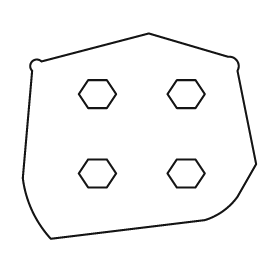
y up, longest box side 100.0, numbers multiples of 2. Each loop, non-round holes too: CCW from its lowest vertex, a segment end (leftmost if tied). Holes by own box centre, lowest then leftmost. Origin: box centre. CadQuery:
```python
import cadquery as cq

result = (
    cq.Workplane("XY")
    .moveTo(-38.0, -44.0)
    .lineTo(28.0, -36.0)
    .threePointArc((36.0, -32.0), (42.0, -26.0))
    .lineTo(50.0, -12.0)
    .lineTo(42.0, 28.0)
    .threePointArc((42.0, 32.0), (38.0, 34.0))
    .lineTo(4.0, 44.0)
    .lineTo(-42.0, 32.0)
    .threePointArc((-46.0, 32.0), (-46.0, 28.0))
    .lineTo(-50.0, -18.0)
    .threePointArc((-46.0, -32.0), (-38.0, -44.0))
    .close()
    .moveTo(-22.0, -22.0)
    .lineTo(-14.0, -22.0)
    .lineTo(-10.0, -16.0)
    .lineTo(-14.0, -10.0)
    .lineTo(-22.0, -10.0)
    .lineTo(-26.0, -16.0)
    .close()
    .moveTo(16.0, -22.0)
    .lineTo(24.0, -22.0)
    .lineTo(28.0, -16.0)
    .lineTo(24.0, -10.0)
    .lineTo(16.0, -10.0)
    .lineTo(12.0, -16.0)
    .close()
    .moveTo(-22.0, 12.0)
    .lineTo(-14.0, 12.0)
    .lineTo(-10.0, 18.0)
    .lineTo(-14.0, 24.0)
    .lineTo(-22.0, 24.0)
    .lineTo(-26.0, 18.0)
    .close()
    .moveTo(16.0, 12.0)
    .lineTo(24.0, 12.0)
    .lineTo(28.0, 18.0)
    .lineTo(24.0, 24.0)
    .lineTo(16.0, 24.0)
    .lineTo(12.0, 18.0)
    .close()
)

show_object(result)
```